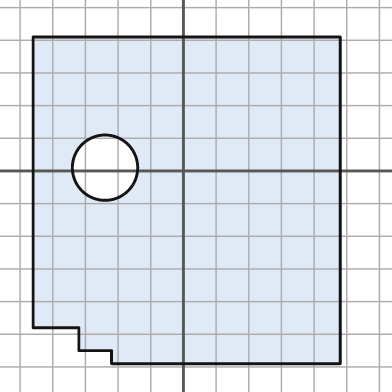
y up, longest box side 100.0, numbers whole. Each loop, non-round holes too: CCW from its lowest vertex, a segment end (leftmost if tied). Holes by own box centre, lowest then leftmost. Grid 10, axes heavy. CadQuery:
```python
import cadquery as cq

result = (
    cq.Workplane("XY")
    .moveTo(-22.0, -59.0)
    .lineTo(48.0, -59.0)
    .lineTo(48.0, 41.0)
    .lineTo(-46.0, 41.0)
    .lineTo(-46.0, -48.0)
    .lineTo(-32.0, -48.0)
    .lineTo(-32.0, -55.0)
    .lineTo(-22.0, -55.0)
    .close()
    .moveTo(-24.0, 1.0)
    .circle(10.0)
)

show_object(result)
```